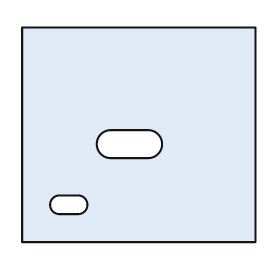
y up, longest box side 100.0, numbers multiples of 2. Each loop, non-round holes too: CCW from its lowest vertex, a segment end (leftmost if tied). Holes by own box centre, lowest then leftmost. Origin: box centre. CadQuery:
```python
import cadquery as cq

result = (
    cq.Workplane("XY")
    .moveTo(-50.0, -46.0)
    .lineTo(50.0, -46.0)
    .lineTo(50.0, 46.0)
    .lineTo(-50.0, 46.0)
    .close()
    .moveTo(-34.0, -34.0)
    .lineTo(-26.0, -34.0)
    .threePointArc((-22.0, -30.0), (-26.0, -26.0))
    .lineTo(-34.0, -26.0)
    .threePointArc((-38.0, -30.0), (-34.0, -34.0))
    .close()
    .moveTo(-12.0, -10.0)
    .lineTo(4.0, -10.0)
    .threePointArc((10.0, -4.0), (4.0, 2.0))
    .lineTo(-12.0, 2.0)
    .threePointArc((-18.0, -4.0), (-12.0, -10.0))
    .close()
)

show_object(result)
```